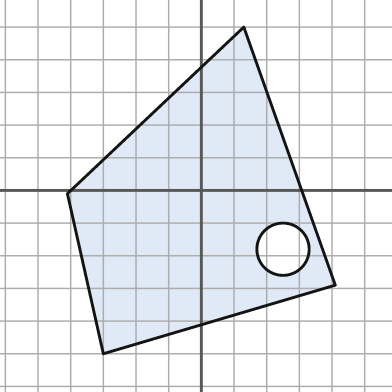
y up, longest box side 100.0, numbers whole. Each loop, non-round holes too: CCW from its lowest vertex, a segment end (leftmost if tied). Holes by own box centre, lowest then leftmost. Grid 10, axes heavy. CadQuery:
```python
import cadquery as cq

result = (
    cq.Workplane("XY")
    .moveTo(-30.0, -50.0)
    .lineTo(41.0, -29.0)
    .lineTo(13.0, 50.0)
    .lineTo(-41.0, -1.0)
    .close()
    .moveTo(25.0, -18.0)
    .circle(8.0)
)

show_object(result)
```